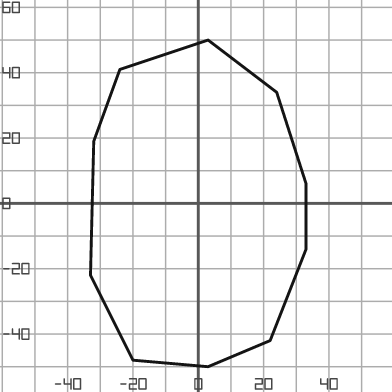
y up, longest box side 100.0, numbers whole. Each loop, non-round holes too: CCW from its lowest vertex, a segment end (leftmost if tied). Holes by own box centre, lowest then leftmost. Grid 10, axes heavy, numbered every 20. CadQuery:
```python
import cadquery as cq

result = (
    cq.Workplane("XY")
    .moveTo(3.0, -50.0)
    .lineTo(22.0, -42.0)
    .lineTo(33.0, -14.0)
    .lineTo(33.0, 6.0)
    .lineTo(24.0, 34.0)
    .lineTo(3.0, 50.0)
    .lineTo(-24.0, 41.0)
    .lineTo(-32.0, 19.0)
    .lineTo(-33.0, -22.0)
    .lineTo(-20.0, -48.0)
    .close()
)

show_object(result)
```